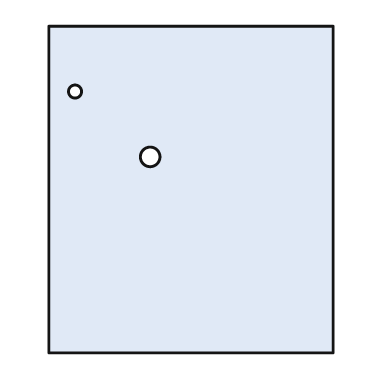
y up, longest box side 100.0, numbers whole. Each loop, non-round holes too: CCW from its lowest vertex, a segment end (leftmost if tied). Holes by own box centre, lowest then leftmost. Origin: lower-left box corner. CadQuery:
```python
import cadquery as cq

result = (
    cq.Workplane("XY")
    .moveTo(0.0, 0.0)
    .lineTo(87.0, 0.0)
    .lineTo(87.0, 100.0)
    .lineTo(0.0, 100.0)
    .close()
    .moveTo(31.0, 60.0)
    .circle(3.0)
    .moveTo(8.0, 80.0)
    .circle(2.0)
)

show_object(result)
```